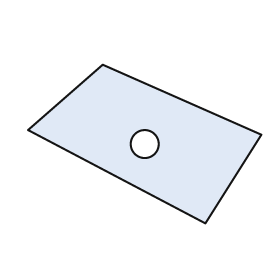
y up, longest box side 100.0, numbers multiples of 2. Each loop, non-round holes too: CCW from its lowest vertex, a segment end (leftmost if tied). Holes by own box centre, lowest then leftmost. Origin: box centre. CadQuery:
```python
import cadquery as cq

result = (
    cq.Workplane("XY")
    .moveTo(26.0, -34.0)
    .lineTo(50.0, 4.0)
    .lineTo(-18.0, 34.0)
    .lineTo(-50.0, 6.0)
    .close()
    .moveTo(0.0, 0.0)
    .circle(6.0)
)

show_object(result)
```